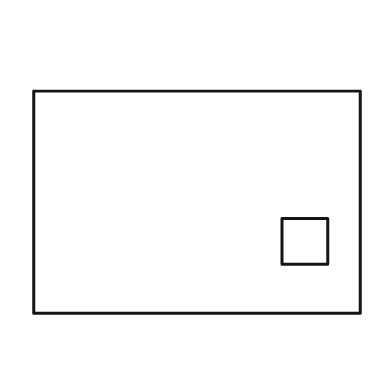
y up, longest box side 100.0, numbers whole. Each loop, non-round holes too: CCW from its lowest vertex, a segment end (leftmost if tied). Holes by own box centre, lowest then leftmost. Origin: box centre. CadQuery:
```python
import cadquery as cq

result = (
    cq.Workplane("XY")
    .moveTo(-50.0, -34.0)
    .lineTo(50.0, -34.0)
    .lineTo(50.0, 34.0)
    .lineTo(-50.0, 34.0)
    .close()
    .moveTo(26.0, -19.0)
    .lineTo(40.0, -19.0)
    .lineTo(40.0, -5.0)
    .lineTo(26.0, -5.0)
    .close()
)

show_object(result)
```